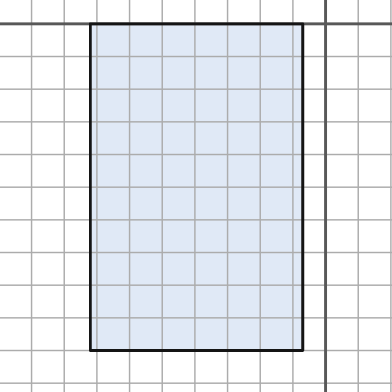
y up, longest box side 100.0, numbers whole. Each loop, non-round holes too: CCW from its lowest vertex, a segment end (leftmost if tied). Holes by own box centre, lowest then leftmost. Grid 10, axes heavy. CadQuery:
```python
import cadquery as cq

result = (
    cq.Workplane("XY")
    .moveTo(-72.0, -100.0)
    .lineTo(-7.0, -100.0)
    .lineTo(-7.0, 0.0)
    .lineTo(-72.0, 0.0)
    .close()
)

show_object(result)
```